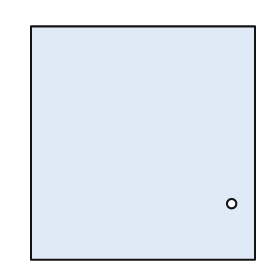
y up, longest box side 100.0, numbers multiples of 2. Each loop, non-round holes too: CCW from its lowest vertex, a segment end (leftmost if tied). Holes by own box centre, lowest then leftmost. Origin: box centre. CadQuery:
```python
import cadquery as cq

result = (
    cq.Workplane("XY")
    .moveTo(-48.0, -50.0)
    .lineTo(48.0, -50.0)
    .lineTo(48.0, 50.0)
    .lineTo(-48.0, 50.0)
    .close()
    .moveTo(38.0, -26.0)
    .circle(2.0)
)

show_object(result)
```